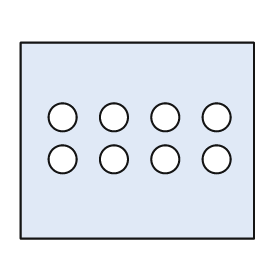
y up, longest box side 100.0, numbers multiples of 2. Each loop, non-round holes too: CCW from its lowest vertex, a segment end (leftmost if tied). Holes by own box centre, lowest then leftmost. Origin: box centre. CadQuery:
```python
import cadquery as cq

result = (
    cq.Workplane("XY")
    .moveTo(-50.0, -42.0)
    .lineTo(50.0, -42.0)
    .lineTo(50.0, 42.0)
    .lineTo(-50.0, 42.0)
    .close()
    .moveTo(-32.0, -8.0)
    .circle(6.0)
    .moveTo(-10.0, -8.0)
    .circle(6.0)
    .moveTo(12.0, -8.0)
    .circle(6.0)
    .moveTo(34.0, -8.0)
    .circle(6.0)
    .moveTo(-32.0, 10.0)
    .circle(6.0)
    .moveTo(-10.0, 10.0)
    .circle(6.0)
    .moveTo(12.0, 10.0)
    .circle(6.0)
    .moveTo(34.0, 10.0)
    .circle(6.0)
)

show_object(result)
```